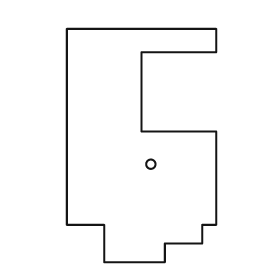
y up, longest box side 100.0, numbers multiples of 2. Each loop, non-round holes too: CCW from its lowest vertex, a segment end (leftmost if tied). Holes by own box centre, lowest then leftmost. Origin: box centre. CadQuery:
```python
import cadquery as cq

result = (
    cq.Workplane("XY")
    .moveTo(-16.0, -50.0)
    .lineTo(10.0, -50.0)
    .lineTo(10.0, -42.0)
    .lineTo(26.0, -42.0)
    .lineTo(26.0, -34.0)
    .lineTo(32.0, -34.0)
    .lineTo(32.0, 6.0)
    .lineTo(0.0, 6.0)
    .lineTo(0.0, 40.0)
    .lineTo(32.0, 40.0)
    .lineTo(32.0, 50.0)
    .lineTo(-32.0, 50.0)
    .lineTo(-32.0, -34.0)
    .lineTo(-16.0, -34.0)
    .close()
    .moveTo(4.0, -8.0)
    .circle(2.0)
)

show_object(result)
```